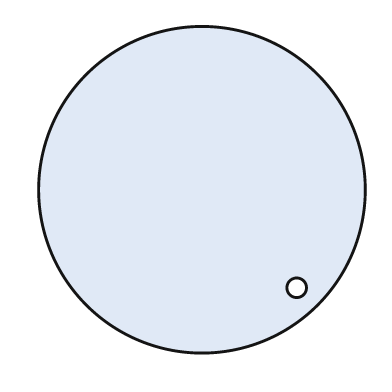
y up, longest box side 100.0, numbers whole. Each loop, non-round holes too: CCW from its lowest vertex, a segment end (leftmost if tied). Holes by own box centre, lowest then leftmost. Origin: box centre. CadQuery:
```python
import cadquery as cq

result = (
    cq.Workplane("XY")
    .moveTo(0.0, 0.0)
    .circle(50.0)
    .moveTo(29.0, -30.0)
    .circle(3.0)
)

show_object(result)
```